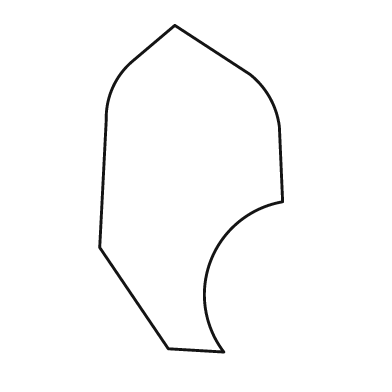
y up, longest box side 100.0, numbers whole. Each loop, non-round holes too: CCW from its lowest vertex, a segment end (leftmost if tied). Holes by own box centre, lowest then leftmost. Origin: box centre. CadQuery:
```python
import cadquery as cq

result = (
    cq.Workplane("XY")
    .moveTo(10.0, -50.0)
    .threePointArc((6.0, -22.0), (28.0, -4.0))
    .lineTo(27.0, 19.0)
    .threePointArc((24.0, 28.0), (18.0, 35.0))
    .lineTo(-5.0, 50.0)
    .lineTo(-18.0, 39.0)
    .threePointArc((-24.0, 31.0), (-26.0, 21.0))
    .lineTo(-28.0, -18.0)
    .lineTo(-7.0, -49.0)
    .close()
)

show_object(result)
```